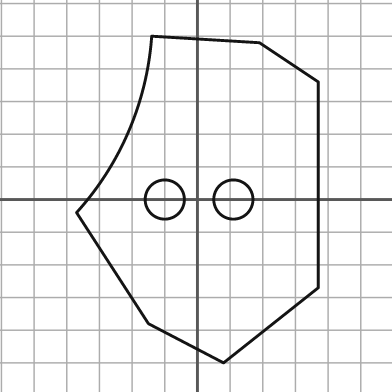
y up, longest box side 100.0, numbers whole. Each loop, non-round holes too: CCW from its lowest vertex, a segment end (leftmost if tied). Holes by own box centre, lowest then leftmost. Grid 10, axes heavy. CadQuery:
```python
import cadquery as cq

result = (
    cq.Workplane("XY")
    .moveTo(8.0, -50.0)
    .lineTo(37.0, -27.0)
    .lineTo(37.0, 36.0)
    .lineTo(19.0, 48.0)
    .lineTo(-14.0, 50.0)
    .threePointArc((-21.0, 21.0), (-37.0, -4.0))
    .lineTo(-15.0, -38.0)
    .close()
    .moveTo(-10.0, 0.0)
    .circle(6.0)
    .moveTo(11.0, 0.0)
    .circle(6.0)
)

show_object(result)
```